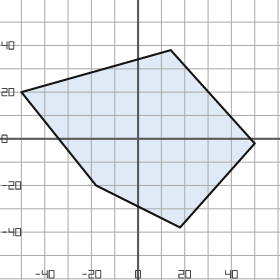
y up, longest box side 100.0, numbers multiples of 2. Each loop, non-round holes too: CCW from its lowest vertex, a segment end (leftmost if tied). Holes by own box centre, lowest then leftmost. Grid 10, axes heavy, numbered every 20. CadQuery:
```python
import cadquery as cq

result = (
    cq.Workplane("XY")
    .moveTo(18.0, -38.0)
    .lineTo(50.0, -2.0)
    .lineTo(14.0, 38.0)
    .lineTo(-50.0, 20.0)
    .lineTo(-18.0, -20.0)
    .close()
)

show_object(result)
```